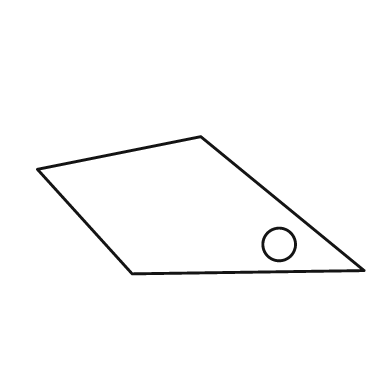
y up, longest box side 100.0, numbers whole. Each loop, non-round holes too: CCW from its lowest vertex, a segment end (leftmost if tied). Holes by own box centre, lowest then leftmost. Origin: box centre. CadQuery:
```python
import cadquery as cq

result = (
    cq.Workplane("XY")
    .moveTo(-21.0, -21.0)
    .lineTo(50.0, -20.0)
    .lineTo(0.0, 21.0)
    .lineTo(-50.0, 11.0)
    .close()
    .moveTo(24.0, -12.0)
    .circle(5.0)
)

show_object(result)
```